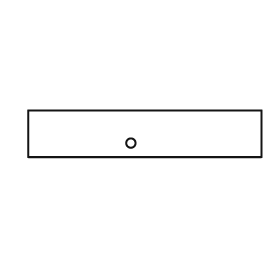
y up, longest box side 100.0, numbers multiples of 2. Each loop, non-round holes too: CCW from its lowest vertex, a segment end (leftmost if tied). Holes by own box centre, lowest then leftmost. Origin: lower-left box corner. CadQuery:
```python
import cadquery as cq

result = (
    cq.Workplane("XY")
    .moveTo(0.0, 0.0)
    .lineTo(100.0, 0.0)
    .lineTo(100.0, 20.0)
    .lineTo(0.0, 20.0)
    .close()
    .moveTo(44.0, 6.0)
    .circle(2.0)
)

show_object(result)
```